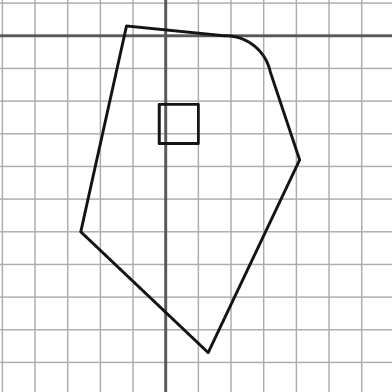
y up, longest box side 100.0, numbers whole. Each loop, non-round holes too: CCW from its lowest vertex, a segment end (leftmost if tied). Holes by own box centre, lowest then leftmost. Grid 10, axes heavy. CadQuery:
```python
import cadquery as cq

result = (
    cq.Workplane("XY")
    .moveTo(13.0, -97.0)
    .lineTo(41.0, -38.0)
    .lineTo(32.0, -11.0)
    .threePointArc((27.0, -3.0), (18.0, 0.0))
    .lineTo(-12.0, 3.0)
    .lineTo(-26.0, -60.0)
    .close()
    .moveTo(-2.0, -33.0)
    .lineTo(10.0, -33.0)
    .lineTo(10.0, -21.0)
    .lineTo(-2.0, -21.0)
    .close()
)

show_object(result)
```